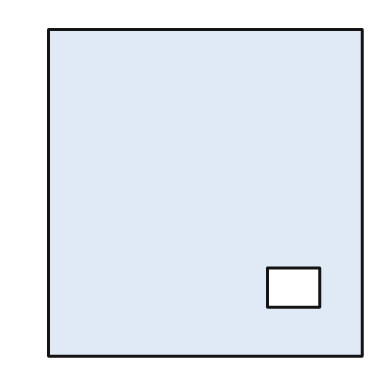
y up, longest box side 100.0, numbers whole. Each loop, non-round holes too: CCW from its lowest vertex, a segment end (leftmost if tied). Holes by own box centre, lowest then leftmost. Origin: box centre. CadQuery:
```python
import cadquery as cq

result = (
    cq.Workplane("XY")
    .moveTo(-48.0, -50.0)
    .lineTo(48.0, -50.0)
    .lineTo(48.0, 50.0)
    .lineTo(-48.0, 50.0)
    .close()
    .moveTo(19.0, -35.0)
    .lineTo(35.0, -35.0)
    .lineTo(35.0, -23.0)
    .lineTo(19.0, -23.0)
    .close()
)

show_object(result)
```